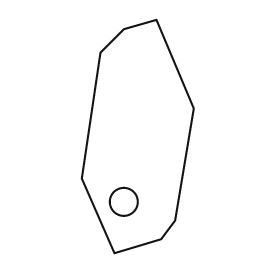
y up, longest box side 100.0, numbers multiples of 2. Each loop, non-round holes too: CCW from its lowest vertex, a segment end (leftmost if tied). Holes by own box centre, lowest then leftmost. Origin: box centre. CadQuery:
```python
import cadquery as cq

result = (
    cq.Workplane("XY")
    .moveTo(-10.0, -50.0)
    .lineTo(10.0, -44.0)
    .lineTo(16.0, -36.0)
    .lineTo(24.0, 12.0)
    .lineTo(8.0, 50.0)
    .lineTo(-6.0, 46.0)
    .lineTo(-16.0, 36.0)
    .lineTo(-24.0, -18.0)
    .close()
    .moveTo(-6.0, -28.0)
    .circle(6.0)
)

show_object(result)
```